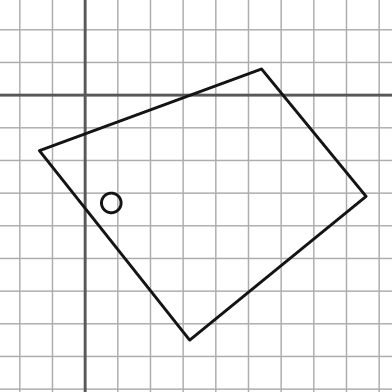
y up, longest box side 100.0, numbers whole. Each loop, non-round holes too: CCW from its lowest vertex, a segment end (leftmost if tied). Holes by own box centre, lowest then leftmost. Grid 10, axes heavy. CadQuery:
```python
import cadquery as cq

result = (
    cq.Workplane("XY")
    .moveTo(32.0, -75.0)
    .lineTo(86.0, -31.0)
    .lineTo(54.0, 8.0)
    .lineTo(-14.0, -17.0)
    .close()
    .moveTo(8.0, -33.0)
    .circle(3.0)
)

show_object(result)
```